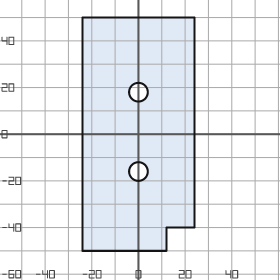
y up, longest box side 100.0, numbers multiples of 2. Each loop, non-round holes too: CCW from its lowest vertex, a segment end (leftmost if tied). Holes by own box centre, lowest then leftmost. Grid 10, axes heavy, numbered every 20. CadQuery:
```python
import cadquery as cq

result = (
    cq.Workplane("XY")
    .moveTo(-24.0, -50.0)
    .lineTo(12.0, -50.0)
    .lineTo(12.0, -40.0)
    .lineTo(24.0, -40.0)
    .lineTo(24.0, 50.0)
    .lineTo(-24.0, 50.0)
    .close()
    .moveTo(0.0, -16.0)
    .circle(4.0)
    .moveTo(0.0, 18.0)
    .circle(4.0)
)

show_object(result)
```